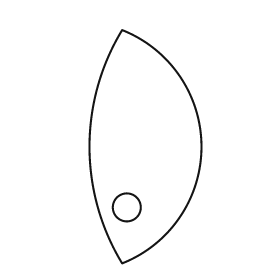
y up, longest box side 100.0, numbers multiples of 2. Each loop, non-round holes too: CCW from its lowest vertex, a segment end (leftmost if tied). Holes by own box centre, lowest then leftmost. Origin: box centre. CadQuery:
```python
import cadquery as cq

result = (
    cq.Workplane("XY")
    .moveTo(-10.0, -50.0)
    .threePointArc((24.0, 0.0), (-10.0, 50.0))
    .threePointArc((-24.0, 0.0), (-10.0, -50.0))
    .close()
    .moveTo(-8.0, -26.0)
    .circle(6.0)
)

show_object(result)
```